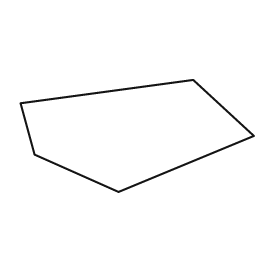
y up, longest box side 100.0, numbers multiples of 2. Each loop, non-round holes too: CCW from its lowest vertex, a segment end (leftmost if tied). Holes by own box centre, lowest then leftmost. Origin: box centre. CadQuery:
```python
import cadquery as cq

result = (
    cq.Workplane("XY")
    .moveTo(-8.0, -24.0)
    .lineTo(50.0, 0.0)
    .lineTo(24.0, 24.0)
    .lineTo(-50.0, 14.0)
    .lineTo(-44.0, -8.0)
    .close()
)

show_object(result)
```